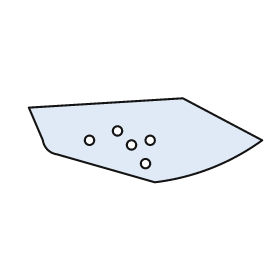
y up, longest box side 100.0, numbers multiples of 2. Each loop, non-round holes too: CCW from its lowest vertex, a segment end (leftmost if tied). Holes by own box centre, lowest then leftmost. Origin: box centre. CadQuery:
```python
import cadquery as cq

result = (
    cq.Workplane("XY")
    .moveTo(4.0, -18.0)
    .threePointArc((28.0, -12.0), (50.0, 0.0))
    .lineTo(16.0, 18.0)
    .lineTo(-50.0, 14.0)
    .lineTo(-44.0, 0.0)
    .threePointArc((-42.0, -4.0), (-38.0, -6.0))
    .close()
    .moveTo(0.0, -10.0)
    .circle(2.0)
    .moveTo(-6.0, -2.0)
    .circle(2.0)
    .moveTo(-24.0, 0.0)
    .circle(2.0)
    .moveTo(2.0, 0.0)
    .circle(2.0)
    .moveTo(-12.0, 4.0)
    .circle(2.0)
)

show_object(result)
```